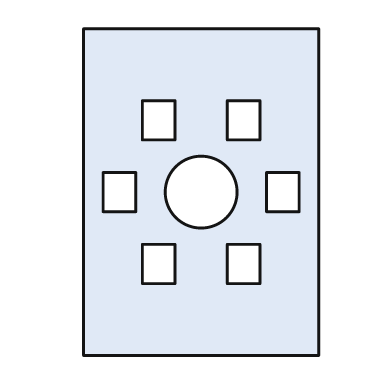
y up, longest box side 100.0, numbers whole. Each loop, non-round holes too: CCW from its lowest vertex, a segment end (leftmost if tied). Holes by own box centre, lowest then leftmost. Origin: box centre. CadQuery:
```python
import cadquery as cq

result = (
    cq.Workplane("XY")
    .moveTo(-36.0, -50.0)
    .lineTo(36.0, -50.0)
    .lineTo(36.0, 50.0)
    .lineTo(-36.0, 50.0)
    .close()
    .moveTo(-18.0, -28.0)
    .lineTo(-8.0, -28.0)
    .lineTo(-8.0, -16.0)
    .lineTo(-18.0, -16.0)
    .close()
    .moveTo(8.0, -28.0)
    .lineTo(18.0, -28.0)
    .lineTo(18.0, -16.0)
    .lineTo(8.0, -16.0)
    .close()
    .moveTo(-30.0, -6.0)
    .lineTo(-20.0, -6.0)
    .lineTo(-20.0, 6.0)
    .lineTo(-30.0, 6.0)
    .close()
    .moveTo(0.0, 0.0)
    .circle(11.0)
    .moveTo(20.0, -6.0)
    .lineTo(30.0, -6.0)
    .lineTo(30.0, 6.0)
    .lineTo(20.0, 6.0)
    .close()
    .moveTo(-18.0, 16.0)
    .lineTo(-8.0, 16.0)
    .lineTo(-8.0, 28.0)
    .lineTo(-18.0, 28.0)
    .close()
    .moveTo(8.0, 16.0)
    .lineTo(18.0, 16.0)
    .lineTo(18.0, 28.0)
    .lineTo(8.0, 28.0)
    .close()
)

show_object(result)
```